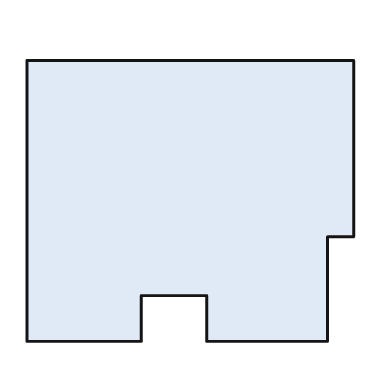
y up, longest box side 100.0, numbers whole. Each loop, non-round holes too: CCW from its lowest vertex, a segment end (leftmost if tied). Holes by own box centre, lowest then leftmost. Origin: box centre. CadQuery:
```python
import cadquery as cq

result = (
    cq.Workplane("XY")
    .moveTo(-50.0, -43.0)
    .lineTo(-15.0, -43.0)
    .lineTo(-15.0, -29.0)
    .lineTo(5.0, -29.0)
    .lineTo(5.0, -43.0)
    .lineTo(42.0, -43.0)
    .lineTo(42.0, -11.0)
    .lineTo(50.0, -11.0)
    .lineTo(50.0, 43.0)
    .lineTo(-50.0, 43.0)
    .close()
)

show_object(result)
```